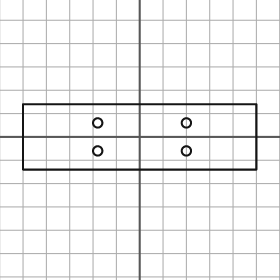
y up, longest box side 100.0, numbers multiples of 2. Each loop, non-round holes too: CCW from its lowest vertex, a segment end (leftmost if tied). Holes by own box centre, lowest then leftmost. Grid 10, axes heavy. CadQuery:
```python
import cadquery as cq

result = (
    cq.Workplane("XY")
    .moveTo(-50.0, -14.0)
    .lineTo(50.0, -14.0)
    .lineTo(50.0, 14.0)
    .lineTo(-50.0, 14.0)
    .close()
    .moveTo(-18.0, -6.0)
    .circle(2.0)
    .moveTo(20.0, -6.0)
    .circle(2.0)
    .moveTo(-18.0, 6.0)
    .circle(2.0)
    .moveTo(20.0, 6.0)
    .circle(2.0)
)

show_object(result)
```